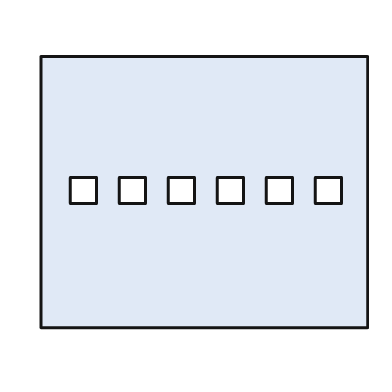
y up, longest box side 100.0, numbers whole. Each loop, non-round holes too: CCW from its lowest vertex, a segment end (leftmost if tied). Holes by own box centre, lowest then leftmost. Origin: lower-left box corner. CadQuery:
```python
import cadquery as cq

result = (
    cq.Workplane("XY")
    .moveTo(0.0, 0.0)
    .lineTo(100.0, 0.0)
    .lineTo(100.0, 83.0)
    .lineTo(0.0, 83.0)
    .close()
    .moveTo(9.0, 38.0)
    .lineTo(17.0, 38.0)
    .lineTo(17.0, 46.0)
    .lineTo(9.0, 46.0)
    .close()
    .moveTo(24.0, 38.0)
    .lineTo(32.0, 38.0)
    .lineTo(32.0, 46.0)
    .lineTo(24.0, 46.0)
    .close()
    .moveTo(39.0, 38.0)
    .lineTo(47.0, 38.0)
    .lineTo(47.0, 46.0)
    .lineTo(39.0, 46.0)
    .close()
    .moveTo(54.0, 38.0)
    .lineTo(62.0, 38.0)
    .lineTo(62.0, 46.0)
    .lineTo(54.0, 46.0)
    .close()
    .moveTo(69.0, 38.0)
    .lineTo(77.0, 38.0)
    .lineTo(77.0, 46.0)
    .lineTo(69.0, 46.0)
    .close()
    .moveTo(84.0, 38.0)
    .lineTo(92.0, 38.0)
    .lineTo(92.0, 46.0)
    .lineTo(84.0, 46.0)
    .close()
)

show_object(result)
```